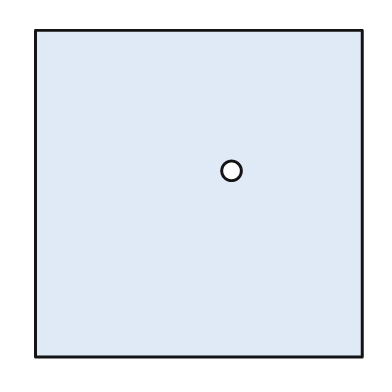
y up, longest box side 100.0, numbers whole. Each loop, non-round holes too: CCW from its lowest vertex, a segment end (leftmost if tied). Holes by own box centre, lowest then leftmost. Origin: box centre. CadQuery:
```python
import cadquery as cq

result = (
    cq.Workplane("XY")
    .moveTo(-50.0, -50.0)
    .lineTo(50.0, -50.0)
    .lineTo(50.0, 50.0)
    .lineTo(-50.0, 50.0)
    .close()
    .moveTo(10.0, 7.0)
    .circle(3.0)
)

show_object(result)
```